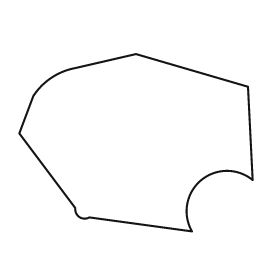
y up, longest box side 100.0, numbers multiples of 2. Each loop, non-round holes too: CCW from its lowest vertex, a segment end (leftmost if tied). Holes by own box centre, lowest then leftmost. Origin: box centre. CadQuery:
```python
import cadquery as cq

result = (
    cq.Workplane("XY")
    .moveTo(24.0, -38.0)
    .threePointArc((28.0, -16.0), (50.0, -16.0))
    .lineTo(48.0, 24.0)
    .lineTo(0.0, 38.0)
    .lineTo(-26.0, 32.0)
    .threePointArc((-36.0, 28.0), (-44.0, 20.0))
    .lineTo(-50.0, 4.0)
    .lineTo(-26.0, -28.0)
    .threePointArc((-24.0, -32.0), (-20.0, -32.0))
    .close()
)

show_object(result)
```